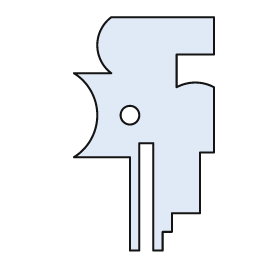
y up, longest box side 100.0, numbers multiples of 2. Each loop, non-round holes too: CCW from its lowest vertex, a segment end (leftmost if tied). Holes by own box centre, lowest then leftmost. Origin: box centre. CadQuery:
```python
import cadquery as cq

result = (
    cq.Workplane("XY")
    .moveTo(-6.0, -50.0)
    .lineTo(-2.0, -50.0)
    .lineTo(-2.0, -4.0)
    .lineTo(4.0, -4.0)
    .lineTo(4.0, -50.0)
    .lineTo(8.0, -50.0)
    .lineTo(8.0, -42.0)
    .lineTo(12.0, -42.0)
    .lineTo(12.0, -34.0)
    .lineTo(24.0, -34.0)
    .lineTo(24.0, -8.0)
    .lineTo(30.0, -8.0)
    .lineTo(30.0, 20.0)
    .threePointArc((22.0, 22.0), (14.0, 20.0))
    .lineTo(14.0, 34.0)
    .lineTo(30.0, 34.0)
    .lineTo(30.0, 50.0)
    .lineTo(-14.0, 50.0)
    .threePointArc((-20.0, 38.0), (-14.0, 26.0))
    .lineTo(-30.0, 26.0)
    .threePointArc((-20.0, 8.0), (-30.0, -10.0))
    .lineTo(-6.0, -10.0)
    .close()
    .moveTo(-6.0, 8.0)
    .circle(4.0)
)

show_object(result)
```